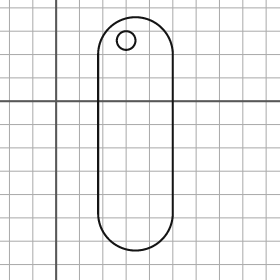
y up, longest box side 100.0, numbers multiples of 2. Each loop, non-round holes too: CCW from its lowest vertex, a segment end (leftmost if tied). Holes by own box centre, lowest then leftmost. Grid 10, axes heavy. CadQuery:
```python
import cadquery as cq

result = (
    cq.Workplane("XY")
    .moveTo(18.0, -48.0)
    .threePointArc((34.0, -64.0), (50.0, -48.0))
    .lineTo(50.0, 20.0)
    .threePointArc((34.0, 36.0), (18.0, 20.0))
    .close()
    .moveTo(30.0, 26.0)
    .circle(4.0)
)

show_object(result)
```